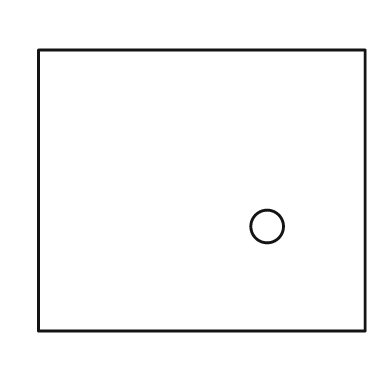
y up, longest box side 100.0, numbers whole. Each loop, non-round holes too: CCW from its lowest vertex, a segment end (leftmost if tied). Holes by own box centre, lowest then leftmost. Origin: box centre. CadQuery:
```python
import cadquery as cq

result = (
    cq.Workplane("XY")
    .moveTo(-50.0, -43.0)
    .lineTo(50.0, -43.0)
    .lineTo(50.0, 43.0)
    .lineTo(-50.0, 43.0)
    .close()
    .moveTo(20.0, -11.0)
    .circle(5.0)
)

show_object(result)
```